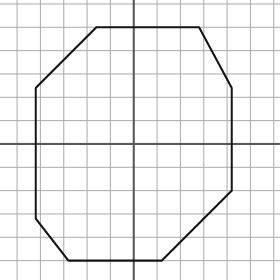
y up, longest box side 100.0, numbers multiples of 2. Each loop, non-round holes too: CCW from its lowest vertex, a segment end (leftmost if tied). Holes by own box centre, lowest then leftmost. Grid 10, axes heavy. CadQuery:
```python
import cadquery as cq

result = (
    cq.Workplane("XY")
    .moveTo(-28.0, -50.0)
    .lineTo(12.0, -50.0)
    .lineTo(42.0, -20.0)
    .lineTo(42.0, 24.0)
    .lineTo(28.0, 50.0)
    .lineTo(-16.0, 50.0)
    .lineTo(-42.0, 24.0)
    .lineTo(-42.0, -32.0)
    .close()
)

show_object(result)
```